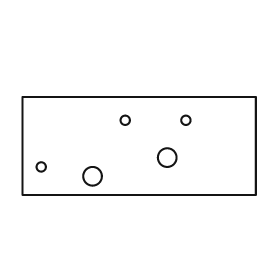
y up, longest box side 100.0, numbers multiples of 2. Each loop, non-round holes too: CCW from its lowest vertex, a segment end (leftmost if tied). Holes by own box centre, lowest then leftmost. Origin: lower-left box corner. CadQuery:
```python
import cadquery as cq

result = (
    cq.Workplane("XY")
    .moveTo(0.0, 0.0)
    .lineTo(100.0, 0.0)
    .lineTo(100.0, 42.0)
    .lineTo(0.0, 42.0)
    .close()
    .moveTo(30.0, 8.0)
    .circle(4.0)
    .moveTo(8.0, 12.0)
    .circle(2.0)
    .moveTo(62.0, 16.0)
    .circle(4.0)
    .moveTo(44.0, 32.0)
    .circle(2.0)
    .moveTo(70.0, 32.0)
    .circle(2.0)
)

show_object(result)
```